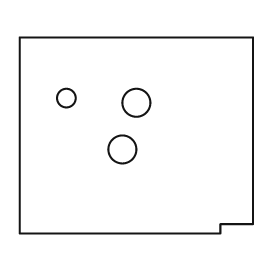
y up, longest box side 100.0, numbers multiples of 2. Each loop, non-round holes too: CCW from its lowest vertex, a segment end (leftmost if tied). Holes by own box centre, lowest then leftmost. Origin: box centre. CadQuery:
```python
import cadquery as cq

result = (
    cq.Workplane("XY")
    .moveTo(-50.0, -42.0)
    .lineTo(36.0, -42.0)
    .lineTo(36.0, -38.0)
    .lineTo(50.0, -38.0)
    .lineTo(50.0, 42.0)
    .lineTo(-50.0, 42.0)
    .close()
    .moveTo(-6.0, -6.0)
    .circle(6.0)
    .moveTo(0.0, 14.0)
    .circle(6.0)
    .moveTo(-30.0, 16.0)
    .circle(4.0)
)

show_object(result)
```